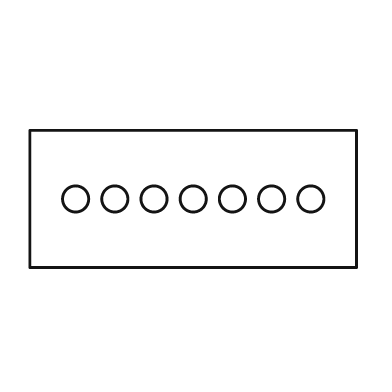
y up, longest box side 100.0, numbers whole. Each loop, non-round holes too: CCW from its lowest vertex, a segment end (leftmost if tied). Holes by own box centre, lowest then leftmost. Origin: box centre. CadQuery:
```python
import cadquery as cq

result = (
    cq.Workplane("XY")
    .moveTo(-50.0, -21.0)
    .lineTo(50.0, -21.0)
    .lineTo(50.0, 21.0)
    .lineTo(-50.0, 21.0)
    .close()
    .moveTo(-36.0, 0.0)
    .circle(4.0)
    .moveTo(-24.0, 0.0)
    .circle(4.0)
    .moveTo(-12.0, 0.0)
    .circle(4.0)
    .moveTo(0.0, 0.0)
    .circle(4.0)
    .moveTo(12.0, 0.0)
    .circle(4.0)
    .moveTo(24.0, 0.0)
    .circle(4.0)
    .moveTo(36.0, 0.0)
    .circle(4.0)
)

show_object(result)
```